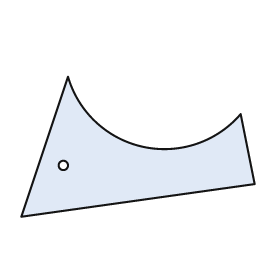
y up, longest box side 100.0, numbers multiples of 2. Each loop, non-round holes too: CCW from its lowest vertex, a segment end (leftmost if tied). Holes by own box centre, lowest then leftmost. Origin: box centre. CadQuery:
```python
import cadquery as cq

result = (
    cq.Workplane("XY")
    .moveTo(-50.0, -30.0)
    .lineTo(50.0, -16.0)
    .lineTo(44.0, 14.0)
    .threePointArc((2.0, 0.0), (-30.0, 30.0))
    .close()
    .moveTo(-32.0, -8.0)
    .circle(2.0)
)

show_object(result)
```